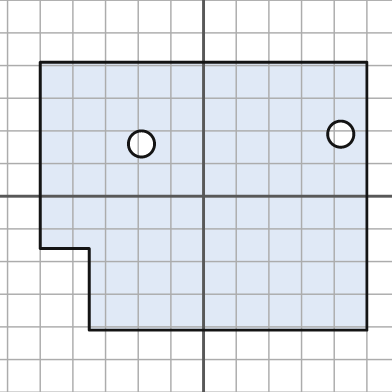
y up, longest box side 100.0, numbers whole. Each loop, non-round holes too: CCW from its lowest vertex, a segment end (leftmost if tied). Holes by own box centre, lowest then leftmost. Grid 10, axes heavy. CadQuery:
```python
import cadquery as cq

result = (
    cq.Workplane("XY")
    .moveTo(-35.0, -41.0)
    .lineTo(50.0, -41.0)
    .lineTo(50.0, 41.0)
    .lineTo(-50.0, 41.0)
    .lineTo(-50.0, -16.0)
    .lineTo(-35.0, -16.0)
    .close()
    .moveTo(-19.0, 16.0)
    .circle(4.0)
    .moveTo(42.0, 19.0)
    .circle(4.0)
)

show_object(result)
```